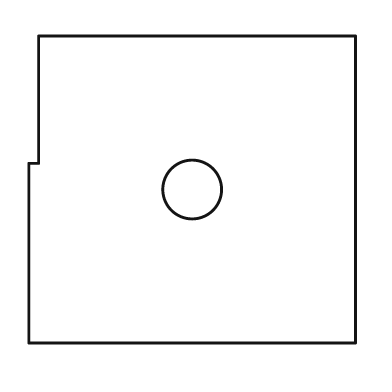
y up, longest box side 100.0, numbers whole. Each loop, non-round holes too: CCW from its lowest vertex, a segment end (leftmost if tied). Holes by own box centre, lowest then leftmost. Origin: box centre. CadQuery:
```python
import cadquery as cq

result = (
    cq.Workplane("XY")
    .moveTo(-50.0, -47.0)
    .lineTo(50.0, -47.0)
    .lineTo(50.0, 47.0)
    .lineTo(-47.0, 47.0)
    .lineTo(-47.0, 8.0)
    .lineTo(-50.0, 8.0)
    .close()
    .moveTo(0.0, 0.0)
    .circle(9.0)
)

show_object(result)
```